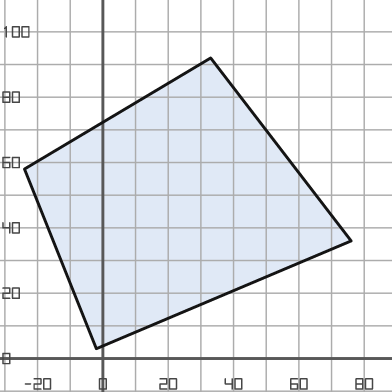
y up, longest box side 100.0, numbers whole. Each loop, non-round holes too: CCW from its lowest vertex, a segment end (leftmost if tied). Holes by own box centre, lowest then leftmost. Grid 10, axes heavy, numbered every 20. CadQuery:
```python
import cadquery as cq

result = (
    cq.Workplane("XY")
    .moveTo(-2.0, 3.0)
    .lineTo(76.0, 36.0)
    .lineTo(33.0, 92.0)
    .lineTo(-24.0, 58.0)
    .close()
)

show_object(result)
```